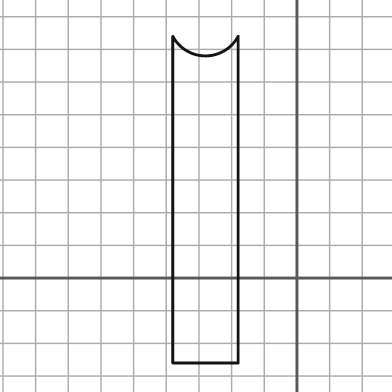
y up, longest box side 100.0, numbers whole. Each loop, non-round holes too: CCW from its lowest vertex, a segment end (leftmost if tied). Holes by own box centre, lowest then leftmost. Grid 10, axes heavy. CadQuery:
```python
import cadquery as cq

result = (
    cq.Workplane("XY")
    .moveTo(-38.0, -26.0)
    .lineTo(-18.0, -26.0)
    .lineTo(-18.0, 74.0)
    .threePointArc((-28.0, 68.0), (-38.0, 74.0))
    .close()
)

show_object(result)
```